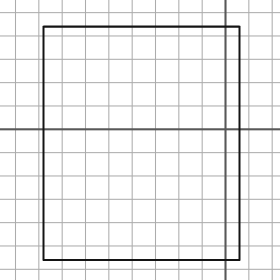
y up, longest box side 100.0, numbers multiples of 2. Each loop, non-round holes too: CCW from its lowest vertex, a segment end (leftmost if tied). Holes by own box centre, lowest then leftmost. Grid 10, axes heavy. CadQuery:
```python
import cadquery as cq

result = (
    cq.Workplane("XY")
    .moveTo(-78.0, -56.0)
    .lineTo(6.0, -56.0)
    .lineTo(6.0, 44.0)
    .lineTo(-78.0, 44.0)
    .close()
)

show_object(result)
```